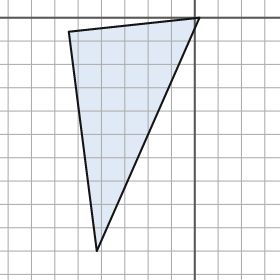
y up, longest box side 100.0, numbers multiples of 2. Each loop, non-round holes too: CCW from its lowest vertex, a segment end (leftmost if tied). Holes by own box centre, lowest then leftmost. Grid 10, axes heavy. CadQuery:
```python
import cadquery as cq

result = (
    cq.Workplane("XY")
    .moveTo(-42.0, -100.0)
    .lineTo(2.0, 0.0)
    .lineTo(-54.0, -6.0)
    .close()
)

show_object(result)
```